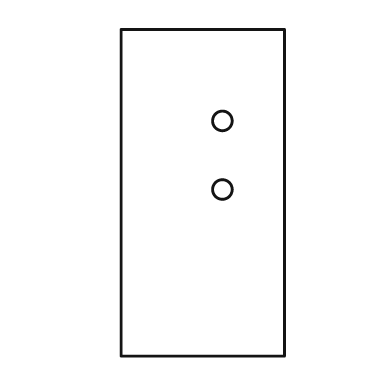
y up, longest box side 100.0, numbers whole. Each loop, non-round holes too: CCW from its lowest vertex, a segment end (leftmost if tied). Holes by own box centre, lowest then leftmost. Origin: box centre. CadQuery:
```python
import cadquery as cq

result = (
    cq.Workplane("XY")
    .moveTo(-25.0, -50.0)
    .lineTo(25.0, -50.0)
    .lineTo(25.0, 50.0)
    .lineTo(-25.0, 50.0)
    .close()
    .moveTo(6.0, 1.0)
    .circle(3.0)
    .moveTo(6.0, 22.0)
    .circle(3.0)
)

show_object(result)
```